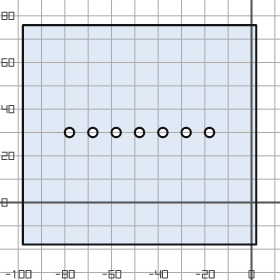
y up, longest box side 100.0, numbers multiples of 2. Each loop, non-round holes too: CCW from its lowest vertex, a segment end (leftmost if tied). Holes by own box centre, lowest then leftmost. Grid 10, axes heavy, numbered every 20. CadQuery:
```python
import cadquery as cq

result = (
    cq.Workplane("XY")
    .moveTo(-98.0, -18.0)
    .lineTo(2.0, -18.0)
    .lineTo(2.0, 76.0)
    .lineTo(-98.0, 76.0)
    .close()
    .moveTo(-78.0, 30.0)
    .circle(2.0)
    .moveTo(-68.0, 30.0)
    .circle(2.0)
    .moveTo(-58.0, 30.0)
    .circle(2.0)
    .moveTo(-48.0, 30.0)
    .circle(2.0)
    .moveTo(-38.0, 30.0)
    .circle(2.0)
    .moveTo(-28.0, 30.0)
    .circle(2.0)
    .moveTo(-18.0, 30.0)
    .circle(2.0)
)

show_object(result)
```